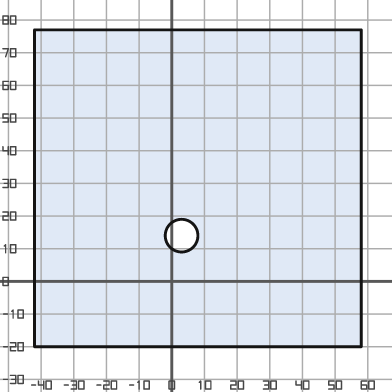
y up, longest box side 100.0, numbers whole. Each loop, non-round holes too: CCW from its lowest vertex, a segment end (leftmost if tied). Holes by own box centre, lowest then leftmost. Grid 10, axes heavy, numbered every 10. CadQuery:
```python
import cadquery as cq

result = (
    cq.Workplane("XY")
    .moveTo(-42.0, -20.0)
    .lineTo(58.0, -20.0)
    .lineTo(58.0, 77.0)
    .lineTo(-42.0, 77.0)
    .close()
    .moveTo(3.0, 14.0)
    .circle(5.0)
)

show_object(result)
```